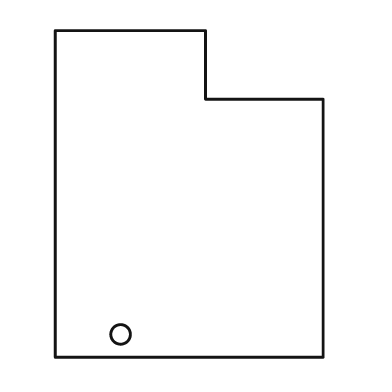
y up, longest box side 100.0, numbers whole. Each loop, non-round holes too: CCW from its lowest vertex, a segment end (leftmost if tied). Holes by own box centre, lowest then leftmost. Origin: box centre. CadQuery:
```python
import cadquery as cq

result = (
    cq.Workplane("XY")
    .moveTo(-41.0, -50.0)
    .lineTo(41.0, -50.0)
    .lineTo(41.0, 29.0)
    .lineTo(5.0, 29.0)
    .lineTo(5.0, 50.0)
    .lineTo(-41.0, 50.0)
    .close()
    .moveTo(-21.0, -43.0)
    .circle(3.0)
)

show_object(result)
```